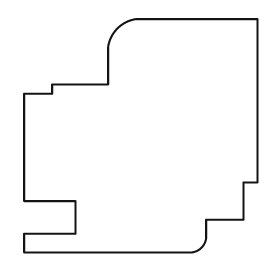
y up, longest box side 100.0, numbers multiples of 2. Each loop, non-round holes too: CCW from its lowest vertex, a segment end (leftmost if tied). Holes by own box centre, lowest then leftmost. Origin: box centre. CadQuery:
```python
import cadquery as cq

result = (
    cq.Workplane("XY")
    .moveTo(-50.0, -50.0)
    .lineTo(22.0, -50.0)
    .threePointArc((26.0, -48.0), (28.0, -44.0))
    .lineTo(28.0, -36.0)
    .lineTo(44.0, -36.0)
    .lineTo(44.0, -20.0)
    .lineTo(50.0, -20.0)
    .lineTo(50.0, 50.0)
    .lineTo(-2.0, 50.0)
    .threePointArc((-10.0, 46.0), (-14.0, 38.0))
    .lineTo(-14.0, 22.0)
    .lineTo(-38.0, 22.0)
    .lineTo(-38.0, 18.0)
    .lineTo(-50.0, 18.0)
    .lineTo(-50.0, -28.0)
    .lineTo(-28.0, -28.0)
    .lineTo(-28.0, -42.0)
    .lineTo(-50.0, -42.0)
    .close()
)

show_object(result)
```